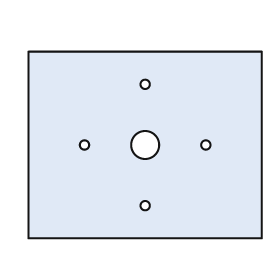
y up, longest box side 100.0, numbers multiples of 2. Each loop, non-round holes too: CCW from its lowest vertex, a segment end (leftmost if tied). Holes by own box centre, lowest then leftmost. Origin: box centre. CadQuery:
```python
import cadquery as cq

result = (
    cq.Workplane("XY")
    .moveTo(-50.0, -40.0)
    .lineTo(50.0, -40.0)
    .lineTo(50.0, 40.0)
    .lineTo(-50.0, 40.0)
    .close()
    .moveTo(0.0, -26.0)
    .circle(2.0)
    .moveTo(-26.0, 0.0)
    .circle(2.0)
    .moveTo(0.0, 0.0)
    .circle(6.0)
    .moveTo(26.0, 0.0)
    .circle(2.0)
    .moveTo(0.0, 26.0)
    .circle(2.0)
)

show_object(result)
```